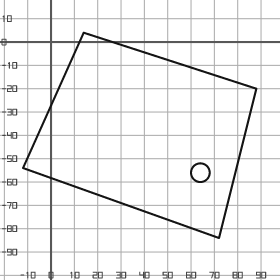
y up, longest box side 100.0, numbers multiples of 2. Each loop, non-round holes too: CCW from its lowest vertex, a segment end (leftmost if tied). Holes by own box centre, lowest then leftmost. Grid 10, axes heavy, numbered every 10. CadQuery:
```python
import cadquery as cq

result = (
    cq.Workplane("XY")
    .moveTo(72.0, -84.0)
    .lineTo(88.0, -20.0)
    .lineTo(14.0, 4.0)
    .lineTo(-12.0, -54.0)
    .close()
    .moveTo(64.0, -56.0)
    .circle(4.0)
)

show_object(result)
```